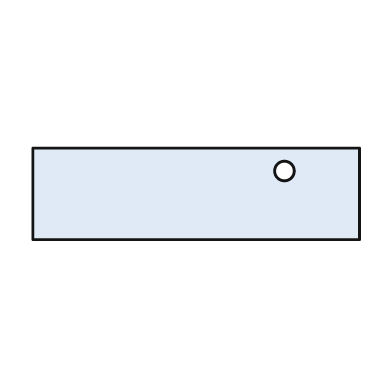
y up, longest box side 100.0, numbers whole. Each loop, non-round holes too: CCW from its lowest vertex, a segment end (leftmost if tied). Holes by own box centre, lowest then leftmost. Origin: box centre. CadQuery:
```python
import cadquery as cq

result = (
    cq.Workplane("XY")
    .moveTo(-50.0, -14.0)
    .lineTo(50.0, -14.0)
    .lineTo(50.0, 14.0)
    .lineTo(-50.0, 14.0)
    .close()
    .moveTo(27.0, 7.0)
    .circle(3.0)
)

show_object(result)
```